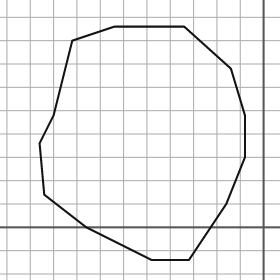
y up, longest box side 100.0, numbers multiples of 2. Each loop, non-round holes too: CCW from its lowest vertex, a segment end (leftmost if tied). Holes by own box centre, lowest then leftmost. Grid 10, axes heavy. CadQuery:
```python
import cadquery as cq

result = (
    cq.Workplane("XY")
    .moveTo(-48.0, -14.0)
    .lineTo(-32.0, -14.0)
    .lineTo(-16.0, 10.0)
    .lineTo(-8.0, 30.0)
    .lineTo(-8.0, 48.0)
    .lineTo(-14.0, 68.0)
    .lineTo(-34.0, 86.0)
    .lineTo(-64.0, 86.0)
    .lineTo(-82.0, 80.0)
    .lineTo(-90.0, 48.0)
    .lineTo(-96.0, 36.0)
    .lineTo(-94.0, 14.0)
    .lineTo(-76.0, 0.0)
    .close()
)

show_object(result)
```